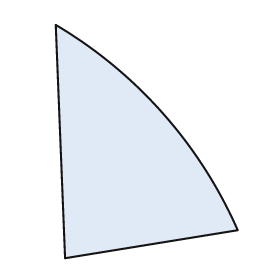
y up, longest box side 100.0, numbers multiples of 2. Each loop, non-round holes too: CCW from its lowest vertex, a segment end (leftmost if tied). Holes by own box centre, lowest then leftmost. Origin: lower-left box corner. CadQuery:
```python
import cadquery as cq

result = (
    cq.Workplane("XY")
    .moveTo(4.0, 0.0)
    .lineTo(78.0, 12.0)
    .threePointArc((46.0, 62.0), (0.0, 100.0))
    .close()
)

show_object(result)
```